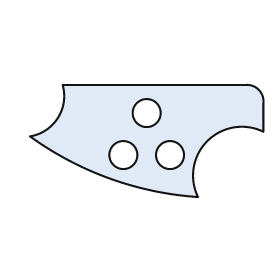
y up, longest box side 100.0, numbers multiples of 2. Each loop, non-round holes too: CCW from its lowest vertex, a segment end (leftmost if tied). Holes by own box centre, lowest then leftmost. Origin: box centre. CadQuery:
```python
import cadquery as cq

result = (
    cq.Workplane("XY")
    .moveTo(22.0, -24.0)
    .threePointArc((26.0, 0.0), (50.0, 4.0))
    .lineTo(50.0, 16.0)
    .threePointArc((48.0, 22.0), (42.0, 24.0))
    .lineTo(-36.0, 24.0)
    .threePointArc((-38.0, 10.0), (-50.0, 2.0))
    .threePointArc((-16.0, -16.0), (22.0, -24.0))
    .close()
    .moveTo(-10.0, -6.0)
    .circle(6.0)
    .moveTo(10.0, -6.0)
    .circle(6.0)
    .moveTo(0.0, 12.0)
    .circle(6.0)
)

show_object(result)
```